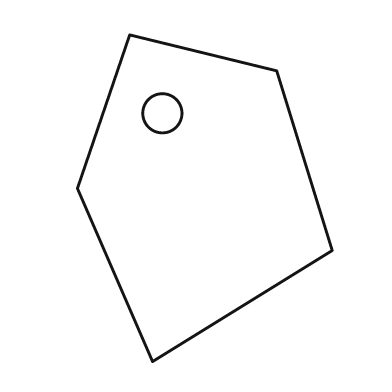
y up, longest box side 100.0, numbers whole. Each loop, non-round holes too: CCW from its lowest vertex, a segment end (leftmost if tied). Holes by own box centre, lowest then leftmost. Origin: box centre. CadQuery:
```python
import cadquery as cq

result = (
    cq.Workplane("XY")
    .moveTo(-16.0, -50.0)
    .lineTo(39.0, -16.0)
    .lineTo(22.0, 39.0)
    .lineTo(-23.0, 50.0)
    .lineTo(-39.0, 3.0)
    .close()
    .moveTo(-13.0, 26.0)
    .circle(6.0)
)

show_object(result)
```